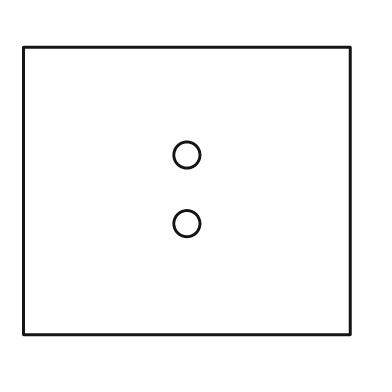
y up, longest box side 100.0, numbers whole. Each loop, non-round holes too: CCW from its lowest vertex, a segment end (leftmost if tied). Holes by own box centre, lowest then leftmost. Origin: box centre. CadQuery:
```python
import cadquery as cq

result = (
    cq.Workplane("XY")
    .moveTo(-50.0, -44.0)
    .lineTo(50.0, -44.0)
    .lineTo(50.0, 44.0)
    .lineTo(-50.0, 44.0)
    .close()
    .moveTo(0.0, -10.0)
    .circle(4.0)
    .moveTo(0.0, 11.0)
    .circle(4.0)
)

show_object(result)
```